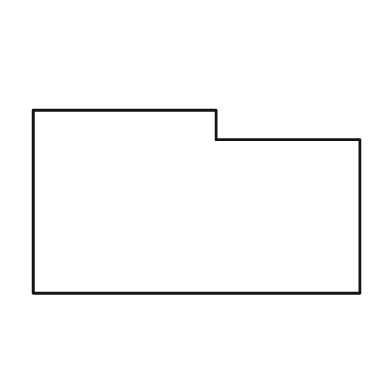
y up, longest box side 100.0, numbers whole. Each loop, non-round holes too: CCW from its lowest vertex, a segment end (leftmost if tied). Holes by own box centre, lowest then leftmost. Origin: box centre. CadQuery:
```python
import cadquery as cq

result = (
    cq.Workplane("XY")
    .moveTo(-50.0, -28.0)
    .lineTo(50.0, -28.0)
    .lineTo(50.0, 19.0)
    .lineTo(6.0, 19.0)
    .lineTo(6.0, 28.0)
    .lineTo(-50.0, 28.0)
    .close()
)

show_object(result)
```